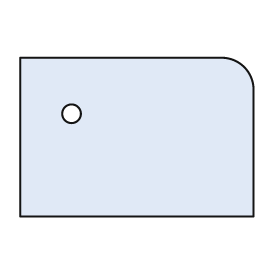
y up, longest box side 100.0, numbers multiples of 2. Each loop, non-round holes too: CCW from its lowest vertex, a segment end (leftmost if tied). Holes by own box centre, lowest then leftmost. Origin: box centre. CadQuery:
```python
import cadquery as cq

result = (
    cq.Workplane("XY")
    .moveTo(-50.0, -34.0)
    .lineTo(50.0, -34.0)
    .lineTo(50.0, 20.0)
    .threePointArc((46.0, 30.0), (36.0, 34.0))
    .lineTo(-50.0, 34.0)
    .close()
    .moveTo(-28.0, 10.0)
    .circle(4.0)
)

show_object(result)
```